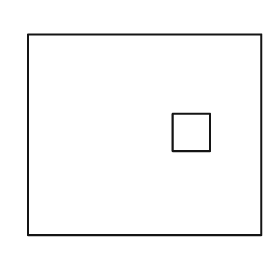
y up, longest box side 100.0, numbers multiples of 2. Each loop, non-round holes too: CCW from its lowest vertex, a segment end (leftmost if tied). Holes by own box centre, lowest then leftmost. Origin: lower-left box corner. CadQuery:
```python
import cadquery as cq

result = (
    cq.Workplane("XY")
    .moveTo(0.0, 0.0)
    .lineTo(100.0, 0.0)
    .lineTo(100.0, 86.0)
    .lineTo(0.0, 86.0)
    .close()
    .moveTo(62.0, 36.0)
    .lineTo(78.0, 36.0)
    .lineTo(78.0, 52.0)
    .lineTo(62.0, 52.0)
    .close()
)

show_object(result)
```